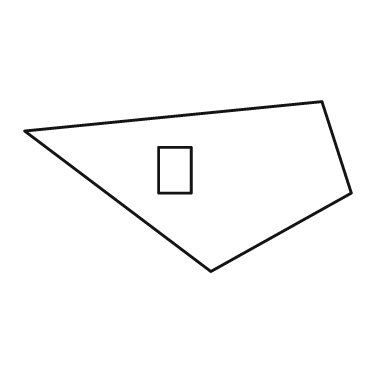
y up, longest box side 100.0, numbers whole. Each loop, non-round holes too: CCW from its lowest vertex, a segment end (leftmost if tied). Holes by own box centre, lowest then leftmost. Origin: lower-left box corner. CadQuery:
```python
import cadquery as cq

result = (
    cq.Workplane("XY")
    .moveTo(57.0, 0.0)
    .lineTo(100.0, 24.0)
    .lineTo(91.0, 52.0)
    .lineTo(0.0, 43.0)
    .close()
    .moveTo(41.0, 24.0)
    .lineTo(51.0, 24.0)
    .lineTo(51.0, 38.0)
    .lineTo(41.0, 38.0)
    .close()
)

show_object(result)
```